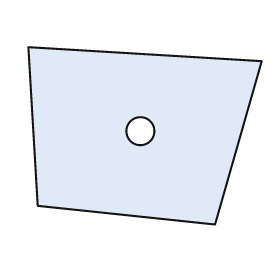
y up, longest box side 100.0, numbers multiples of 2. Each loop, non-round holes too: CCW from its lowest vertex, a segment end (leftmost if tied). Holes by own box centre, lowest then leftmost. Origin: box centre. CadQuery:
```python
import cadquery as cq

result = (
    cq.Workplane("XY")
    .moveTo(30.0, -38.0)
    .lineTo(50.0, 32.0)
    .lineTo(-50.0, 38.0)
    .lineTo(-46.0, -30.0)
    .close()
    .moveTo(-2.0, 2.0)
    .circle(6.0)
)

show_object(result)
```